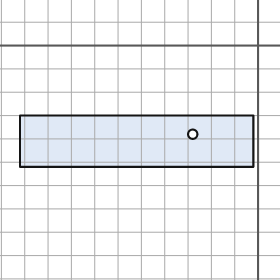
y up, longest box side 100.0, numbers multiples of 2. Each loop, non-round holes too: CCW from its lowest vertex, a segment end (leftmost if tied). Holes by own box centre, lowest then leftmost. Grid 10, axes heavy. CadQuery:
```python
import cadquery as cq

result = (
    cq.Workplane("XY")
    .moveTo(-102.0, -52.0)
    .lineTo(-2.0, -52.0)
    .lineTo(-2.0, -30.0)
    .lineTo(-102.0, -30.0)
    .close()
    .moveTo(-28.0, -38.0)
    .circle(2.0)
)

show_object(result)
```